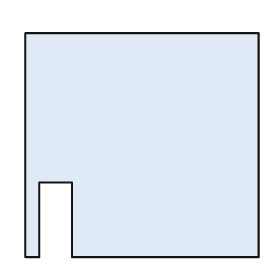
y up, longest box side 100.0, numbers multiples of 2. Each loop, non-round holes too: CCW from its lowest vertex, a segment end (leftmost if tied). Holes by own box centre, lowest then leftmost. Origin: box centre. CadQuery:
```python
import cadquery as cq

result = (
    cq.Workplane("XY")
    .moveTo(-50.0, -48.0)
    .lineTo(-44.0, -48.0)
    .lineTo(-44.0, -16.0)
    .lineTo(-30.0, -16.0)
    .lineTo(-30.0, -48.0)
    .lineTo(50.0, -48.0)
    .lineTo(50.0, 48.0)
    .lineTo(-50.0, 48.0)
    .close()
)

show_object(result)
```